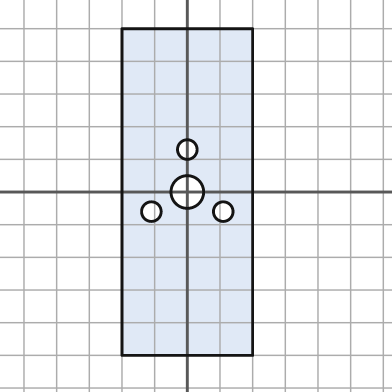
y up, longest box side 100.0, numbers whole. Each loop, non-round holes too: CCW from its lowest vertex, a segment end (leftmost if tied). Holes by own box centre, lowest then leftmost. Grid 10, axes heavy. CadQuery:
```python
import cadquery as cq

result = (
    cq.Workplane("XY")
    .moveTo(-20.0, -50.0)
    .lineTo(20.0, -50.0)
    .lineTo(20.0, 50.0)
    .lineTo(-20.0, 50.0)
    .close()
    .moveTo(-11.0, -6.0)
    .circle(3.0)
    .moveTo(11.0, -6.0)
    .circle(3.0)
    .moveTo(0.0, 0.0)
    .circle(5.0)
    .moveTo(0.0, 13.0)
    .circle(3.0)
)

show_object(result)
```